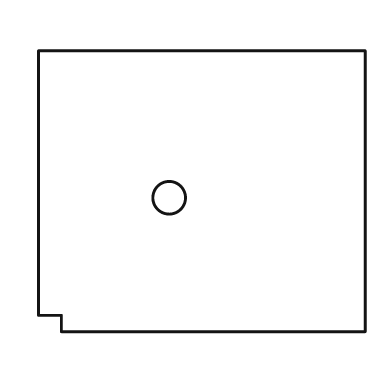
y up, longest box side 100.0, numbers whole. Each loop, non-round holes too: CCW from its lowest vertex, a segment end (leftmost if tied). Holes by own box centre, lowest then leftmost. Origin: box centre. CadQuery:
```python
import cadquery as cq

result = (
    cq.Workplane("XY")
    .moveTo(-43.0, -43.0)
    .lineTo(50.0, -43.0)
    .lineTo(50.0, 43.0)
    .lineTo(-50.0, 43.0)
    .lineTo(-50.0, -38.0)
    .lineTo(-43.0, -38.0)
    .close()
    .moveTo(-10.0, -2.0)
    .circle(5.0)
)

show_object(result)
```